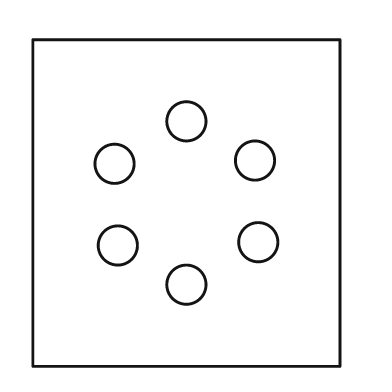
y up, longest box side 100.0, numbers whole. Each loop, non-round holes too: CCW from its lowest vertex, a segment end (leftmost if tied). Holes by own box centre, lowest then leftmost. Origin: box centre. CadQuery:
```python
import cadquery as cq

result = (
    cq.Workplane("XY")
    .moveTo(-47.0, -50.0)
    .lineTo(47.0, -50.0)
    .lineTo(47.0, 50.0)
    .lineTo(-47.0, 50.0)
    .close()
    .moveTo(0.0, -25.0)
    .circle(6.0)
    .moveTo(-21.0, -13.0)
    .circle(6.0)
    .moveTo(22.0, -12.0)
    .circle(6.0)
    .moveTo(-22.0, 12.0)
    .circle(6.0)
    .moveTo(21.0, 13.0)
    .circle(6.0)
    .moveTo(0.0, 25.0)
    .circle(6.0)
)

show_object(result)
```